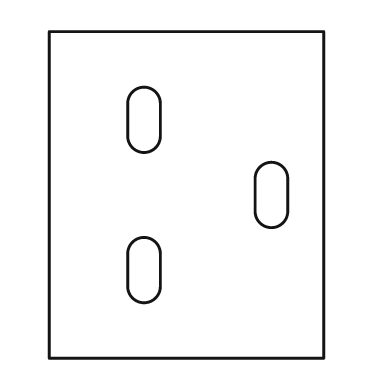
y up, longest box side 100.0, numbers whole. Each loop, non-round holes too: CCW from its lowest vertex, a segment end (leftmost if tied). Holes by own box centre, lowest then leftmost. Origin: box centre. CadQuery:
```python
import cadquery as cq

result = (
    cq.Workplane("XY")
    .moveTo(-42.0, -50.0)
    .lineTo(42.0, -50.0)
    .lineTo(42.0, 50.0)
    .lineTo(-42.0, 50.0)
    .close()
    .moveTo(-18.0, -28.0)
    .threePointArc((-13.0, -33.0), (-8.0, -28.0))
    .lineTo(-8.0, -18.0)
    .threePointArc((-13.0, -13.0), (-18.0, -18.0))
    .close()
    .moveTo(21.0, -5.0)
    .threePointArc((26.0, -10.0), (31.0, -5.0))
    .lineTo(31.0, 5.0)
    .threePointArc((26.0, 10.0), (21.0, 5.0))
    .close()
    .moveTo(-18.0, 18.0)
    .threePointArc((-13.0, 13.0), (-8.0, 18.0))
    .lineTo(-8.0, 28.0)
    .threePointArc((-13.0, 33.0), (-18.0, 28.0))
    .close()
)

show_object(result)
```